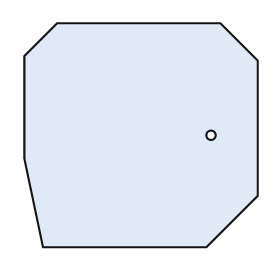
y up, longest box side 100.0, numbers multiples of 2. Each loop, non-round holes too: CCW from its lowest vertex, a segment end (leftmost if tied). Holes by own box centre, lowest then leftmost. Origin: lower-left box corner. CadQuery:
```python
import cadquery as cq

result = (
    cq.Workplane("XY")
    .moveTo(8.0, 0.0)
    .lineTo(78.0, 0.0)
    .lineTo(100.0, 22.0)
    .lineTo(100.0, 80.0)
    .lineTo(84.0, 96.0)
    .lineTo(14.0, 96.0)
    .lineTo(0.0, 82.0)
    .lineTo(0.0, 38.0)
    .close()
    .moveTo(80.0, 48.0)
    .circle(2.0)
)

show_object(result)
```